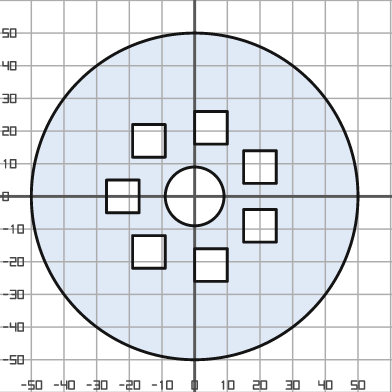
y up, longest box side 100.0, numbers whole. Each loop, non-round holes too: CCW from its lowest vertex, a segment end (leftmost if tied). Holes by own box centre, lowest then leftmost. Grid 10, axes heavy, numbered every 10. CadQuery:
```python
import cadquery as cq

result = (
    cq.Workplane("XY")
    .moveTo(0.0, 0.0)
    .circle(50.0)
    .moveTo(0.0, -26.0)
    .lineTo(10.0, -26.0)
    .lineTo(10.0, -16.0)
    .lineTo(0.0, -16.0)
    .close()
    .moveTo(-19.0, -22.0)
    .lineTo(-9.0, -22.0)
    .lineTo(-9.0, -12.0)
    .lineTo(-19.0, -12.0)
    .close()
    .moveTo(15.0, -14.0)
    .lineTo(25.0, -14.0)
    .lineTo(25.0, -4.0)
    .lineTo(15.0, -4.0)
    .close()
    .moveTo(-27.0, -5.0)
    .lineTo(-17.0, -5.0)
    .lineTo(-17.0, 5.0)
    .lineTo(-27.0, 5.0)
    .close()
    .moveTo(0.0, 0.0)
    .circle(9.0)
    .moveTo(15.0, 4.0)
    .lineTo(25.0, 4.0)
    .lineTo(25.0, 14.0)
    .lineTo(15.0, 14.0)
    .close()
    .moveTo(-19.0, 12.0)
    .lineTo(-9.0, 12.0)
    .lineTo(-9.0, 22.0)
    .lineTo(-19.0, 22.0)
    .close()
    .moveTo(0.0, 16.0)
    .lineTo(10.0, 16.0)
    .lineTo(10.0, 26.0)
    .lineTo(0.0, 26.0)
    .close()
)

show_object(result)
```